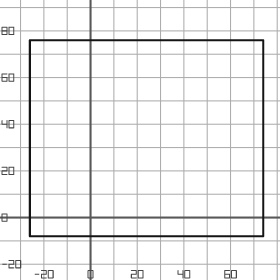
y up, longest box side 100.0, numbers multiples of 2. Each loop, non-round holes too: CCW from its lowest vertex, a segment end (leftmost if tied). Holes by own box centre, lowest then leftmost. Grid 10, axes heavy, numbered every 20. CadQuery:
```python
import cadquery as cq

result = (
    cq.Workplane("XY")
    .moveTo(-26.0, -8.0)
    .lineTo(74.0, -8.0)
    .lineTo(74.0, 76.0)
    .lineTo(-26.0, 76.0)
    .close()
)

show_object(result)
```